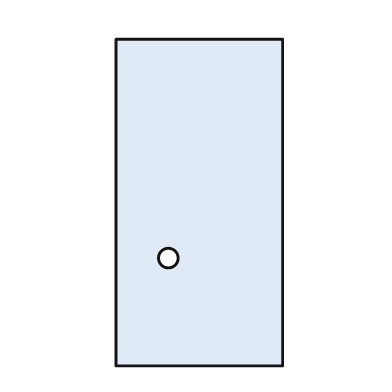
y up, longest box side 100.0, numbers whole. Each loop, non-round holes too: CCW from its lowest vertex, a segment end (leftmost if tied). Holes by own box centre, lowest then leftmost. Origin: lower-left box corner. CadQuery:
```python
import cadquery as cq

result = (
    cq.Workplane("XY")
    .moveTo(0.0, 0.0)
    .lineTo(51.0, 0.0)
    .lineTo(51.0, 100.0)
    .lineTo(0.0, 100.0)
    .close()
    .moveTo(16.0, 33.0)
    .circle(3.0)
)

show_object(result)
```